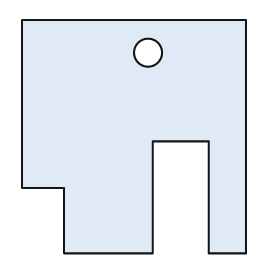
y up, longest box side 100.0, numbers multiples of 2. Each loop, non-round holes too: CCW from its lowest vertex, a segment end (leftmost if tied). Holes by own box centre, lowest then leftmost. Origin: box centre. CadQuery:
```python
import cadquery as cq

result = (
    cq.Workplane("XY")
    .moveTo(-30.0, -50.0)
    .lineTo(8.0, -50.0)
    .lineTo(8.0, -2.0)
    .lineTo(32.0, -2.0)
    .lineTo(32.0, -50.0)
    .lineTo(48.0, -50.0)
    .lineTo(48.0, 50.0)
    .lineTo(-48.0, 50.0)
    .lineTo(-48.0, -22.0)
    .lineTo(-30.0, -22.0)
    .close()
    .moveTo(6.0, 36.0)
    .circle(6.0)
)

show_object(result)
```